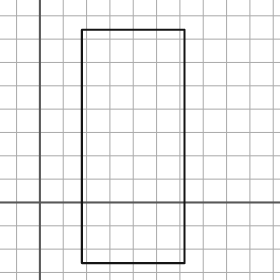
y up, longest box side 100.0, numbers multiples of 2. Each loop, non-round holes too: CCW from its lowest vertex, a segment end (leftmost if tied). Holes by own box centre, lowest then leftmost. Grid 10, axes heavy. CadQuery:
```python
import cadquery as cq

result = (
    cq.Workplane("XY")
    .moveTo(18.0, -26.0)
    .lineTo(62.0, -26.0)
    .lineTo(62.0, 74.0)
    .lineTo(18.0, 74.0)
    .close()
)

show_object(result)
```